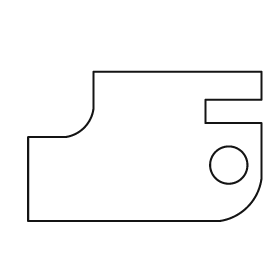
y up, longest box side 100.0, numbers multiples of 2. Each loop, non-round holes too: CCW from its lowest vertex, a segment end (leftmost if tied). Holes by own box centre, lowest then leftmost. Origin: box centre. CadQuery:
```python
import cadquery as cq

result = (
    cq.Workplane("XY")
    .moveTo(-50.0, -32.0)
    .lineTo(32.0, -32.0)
    .threePointArc((44.0, -26.0), (50.0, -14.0))
    .lineTo(50.0, 10.0)
    .lineTo(26.0, 10.0)
    .lineTo(26.0, 20.0)
    .lineTo(50.0, 20.0)
    .lineTo(50.0, 32.0)
    .lineTo(-22.0, 32.0)
    .lineTo(-22.0, 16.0)
    .threePointArc((-26.0, 8.0), (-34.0, 4.0))
    .lineTo(-50.0, 4.0)
    .close()
    .moveTo(36.0, -8.0)
    .circle(8.0)
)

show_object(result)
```